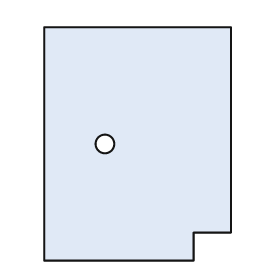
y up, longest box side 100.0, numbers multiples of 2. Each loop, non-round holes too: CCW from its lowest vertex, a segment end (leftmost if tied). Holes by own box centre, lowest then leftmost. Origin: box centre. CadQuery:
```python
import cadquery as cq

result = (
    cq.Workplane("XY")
    .moveTo(-40.0, -50.0)
    .lineTo(24.0, -50.0)
    .lineTo(24.0, -38.0)
    .lineTo(40.0, -38.0)
    .lineTo(40.0, 50.0)
    .lineTo(-40.0, 50.0)
    .close()
    .moveTo(-14.0, 0.0)
    .circle(4.0)
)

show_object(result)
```